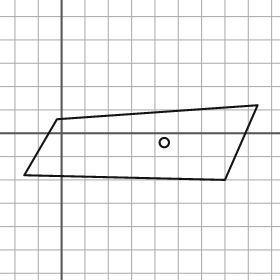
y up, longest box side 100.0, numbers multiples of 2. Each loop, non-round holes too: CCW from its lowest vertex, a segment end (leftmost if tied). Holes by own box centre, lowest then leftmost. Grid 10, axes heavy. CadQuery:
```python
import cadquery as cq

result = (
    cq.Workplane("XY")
    .moveTo(70.0, -20.0)
    .lineTo(84.0, 12.0)
    .lineTo(-2.0, 6.0)
    .lineTo(-16.0, -18.0)
    .close()
    .moveTo(44.0, -4.0)
    .circle(2.0)
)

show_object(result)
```